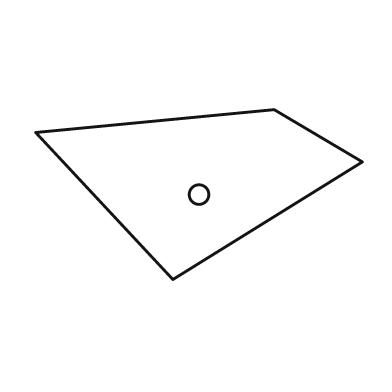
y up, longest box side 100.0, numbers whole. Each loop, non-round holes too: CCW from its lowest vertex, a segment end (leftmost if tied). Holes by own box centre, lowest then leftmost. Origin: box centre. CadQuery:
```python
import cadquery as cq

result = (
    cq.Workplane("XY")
    .moveTo(-8.0, -26.0)
    .lineTo(50.0, 10.0)
    .lineTo(23.0, 26.0)
    .lineTo(-50.0, 19.0)
    .close()
    .moveTo(0.0, 0.0)
    .circle(3.0)
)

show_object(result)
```